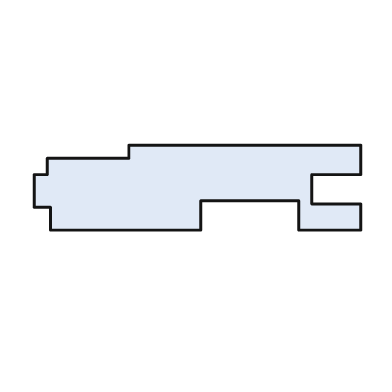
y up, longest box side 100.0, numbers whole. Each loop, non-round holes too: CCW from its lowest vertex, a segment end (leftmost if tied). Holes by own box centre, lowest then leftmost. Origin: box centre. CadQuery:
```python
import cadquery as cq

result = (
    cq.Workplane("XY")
    .moveTo(-45.0, -13.0)
    .lineTo(1.0, -13.0)
    .lineTo(1.0, -4.0)
    .lineTo(31.0, -4.0)
    .lineTo(31.0, -13.0)
    .lineTo(50.0, -13.0)
    .lineTo(50.0, -5.0)
    .lineTo(35.0, -5.0)
    .lineTo(35.0, 4.0)
    .lineTo(50.0, 4.0)
    .lineTo(50.0, 13.0)
    .lineTo(-21.0, 13.0)
    .lineTo(-21.0, 9.0)
    .lineTo(-46.0, 9.0)
    .lineTo(-46.0, 4.0)
    .lineTo(-50.0, 4.0)
    .lineTo(-50.0, -6.0)
    .lineTo(-45.0, -6.0)
    .close()
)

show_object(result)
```